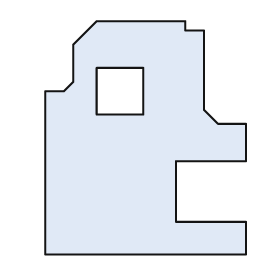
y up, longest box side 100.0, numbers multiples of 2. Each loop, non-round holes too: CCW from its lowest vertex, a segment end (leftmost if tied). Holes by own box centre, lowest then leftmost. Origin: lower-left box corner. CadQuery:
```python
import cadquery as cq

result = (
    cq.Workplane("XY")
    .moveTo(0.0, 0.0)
    .lineTo(86.0, 0.0)
    .lineTo(86.0, 14.0)
    .lineTo(56.0, 14.0)
    .lineTo(56.0, 40.0)
    .lineTo(86.0, 40.0)
    .lineTo(86.0, 56.0)
    .lineTo(74.0, 56.0)
    .lineTo(68.0, 62.0)
    .lineTo(68.0, 96.0)
    .lineTo(60.0, 96.0)
    .lineTo(60.0, 100.0)
    .lineTo(22.0, 100.0)
    .lineTo(12.0, 90.0)
    .lineTo(12.0, 74.0)
    .lineTo(8.0, 70.0)
    .lineTo(0.0, 70.0)
    .close()
    .moveTo(22.0, 60.0)
    .lineTo(42.0, 60.0)
    .lineTo(42.0, 80.0)
    .lineTo(22.0, 80.0)
    .close()
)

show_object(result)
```